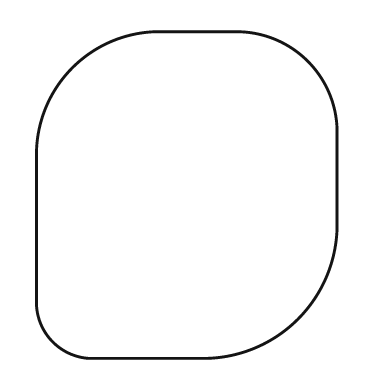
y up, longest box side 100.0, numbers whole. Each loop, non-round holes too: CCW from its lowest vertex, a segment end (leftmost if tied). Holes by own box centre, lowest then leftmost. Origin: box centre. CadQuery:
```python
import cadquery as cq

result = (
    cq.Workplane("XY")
    .moveTo(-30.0, -50.0)
    .lineTo(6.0, -50.0)
    .threePointArc((34.0, -38.0), (46.0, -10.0))
    .lineTo(46.0, 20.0)
    .threePointArc((37.0, 41.0), (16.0, 50.0))
    .lineTo(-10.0, 50.0)
    .threePointArc((-35.0, 39.0), (-46.0, 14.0))
    .lineTo(-46.0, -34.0)
    .threePointArc((-41.0, -45.0), (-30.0, -50.0))
    .close()
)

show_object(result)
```